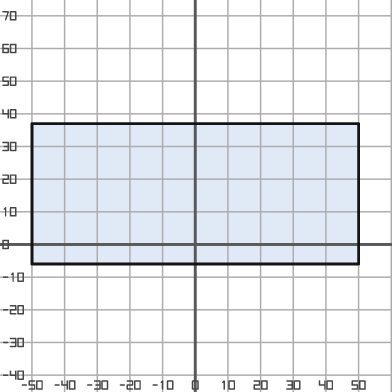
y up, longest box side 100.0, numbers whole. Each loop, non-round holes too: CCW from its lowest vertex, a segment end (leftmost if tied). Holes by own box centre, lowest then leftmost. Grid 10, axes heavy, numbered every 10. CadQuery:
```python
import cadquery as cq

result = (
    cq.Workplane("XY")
    .moveTo(-50.0, -6.0)
    .lineTo(50.0, -6.0)
    .lineTo(50.0, 37.0)
    .lineTo(-50.0, 37.0)
    .close()
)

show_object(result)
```